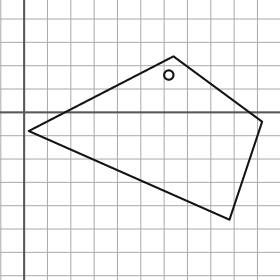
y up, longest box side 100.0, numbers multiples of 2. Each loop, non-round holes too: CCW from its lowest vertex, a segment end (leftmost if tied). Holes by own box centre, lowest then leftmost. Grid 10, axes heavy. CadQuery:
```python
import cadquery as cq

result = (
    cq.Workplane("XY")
    .moveTo(88.0, -46.0)
    .lineTo(102.0, -4.0)
    .lineTo(64.0, 24.0)
    .lineTo(2.0, -8.0)
    .close()
    .moveTo(62.0, 16.0)
    .circle(2.0)
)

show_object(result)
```